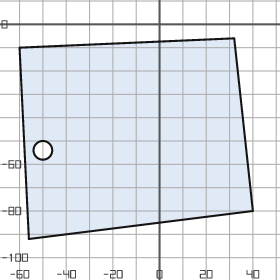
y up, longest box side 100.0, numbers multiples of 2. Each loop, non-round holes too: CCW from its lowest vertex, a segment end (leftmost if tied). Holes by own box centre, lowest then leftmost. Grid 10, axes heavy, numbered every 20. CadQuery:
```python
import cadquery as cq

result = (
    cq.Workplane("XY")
    .moveTo(-56.0, -92.0)
    .lineTo(40.0, -80.0)
    .lineTo(32.0, -6.0)
    .lineTo(-60.0, -10.0)
    .close()
    .moveTo(-50.0, -54.0)
    .circle(4.0)
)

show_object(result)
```